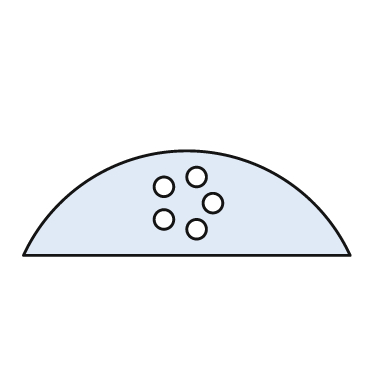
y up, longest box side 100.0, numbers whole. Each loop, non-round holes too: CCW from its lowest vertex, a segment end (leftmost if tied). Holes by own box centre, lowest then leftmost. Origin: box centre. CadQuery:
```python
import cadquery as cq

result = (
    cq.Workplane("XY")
    .moveTo(-50.0, -16.0)
    .lineTo(50.0, -16.0)
    .threePointArc((0.0, 16.0), (-50.0, -16.0))
    .close()
    .moveTo(3.0, -8.0)
    .circle(3.0)
    .moveTo(-7.0, -5.0)
    .circle(3.0)
    .moveTo(8.0, 0.0)
    .circle(3.0)
    .moveTo(-7.0, 5.0)
    .circle(3.0)
    .moveTo(3.0, 8.0)
    .circle(3.0)
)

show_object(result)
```